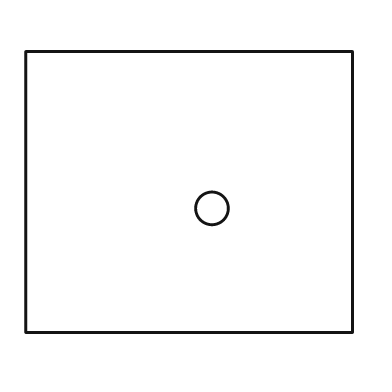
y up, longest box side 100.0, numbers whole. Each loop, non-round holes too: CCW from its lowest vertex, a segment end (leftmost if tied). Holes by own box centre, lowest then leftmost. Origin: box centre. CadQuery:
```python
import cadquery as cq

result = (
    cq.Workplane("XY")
    .moveTo(-50.0, -43.0)
    .lineTo(50.0, -43.0)
    .lineTo(50.0, 43.0)
    .lineTo(-50.0, 43.0)
    .close()
    .moveTo(7.0, -5.0)
    .circle(5.0)
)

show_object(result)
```